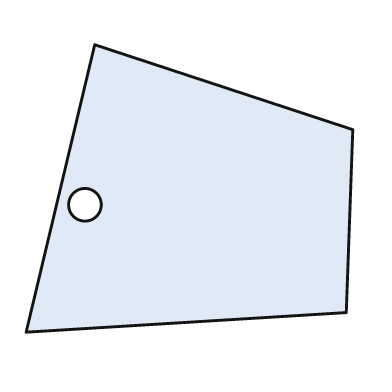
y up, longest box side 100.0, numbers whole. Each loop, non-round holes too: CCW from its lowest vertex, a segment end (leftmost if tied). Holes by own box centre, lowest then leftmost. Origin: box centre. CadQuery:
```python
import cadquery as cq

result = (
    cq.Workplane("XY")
    .moveTo(-50.0, -44.0)
    .lineTo(48.0, -38.0)
    .lineTo(50.0, 18.0)
    .lineTo(-29.0, 44.0)
    .close()
    .moveTo(-32.0, -5.0)
    .circle(5.0)
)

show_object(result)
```